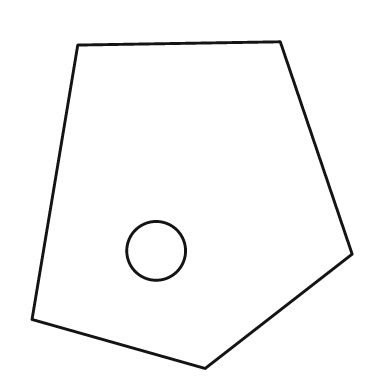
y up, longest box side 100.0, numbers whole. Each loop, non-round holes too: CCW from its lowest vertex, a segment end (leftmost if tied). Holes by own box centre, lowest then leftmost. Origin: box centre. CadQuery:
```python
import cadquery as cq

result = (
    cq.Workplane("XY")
    .moveTo(4.0, -50.0)
    .lineTo(49.0, -15.0)
    .lineTo(27.0, 50.0)
    .lineTo(-35.0, 49.0)
    .lineTo(-49.0, -35.0)
    .close()
    .moveTo(-11.0, -14.0)
    .circle(9.0)
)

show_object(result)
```